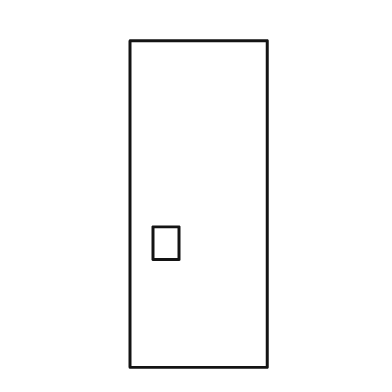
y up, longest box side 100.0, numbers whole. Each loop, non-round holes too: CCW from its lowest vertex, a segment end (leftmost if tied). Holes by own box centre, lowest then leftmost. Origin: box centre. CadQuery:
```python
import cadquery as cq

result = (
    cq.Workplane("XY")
    .moveTo(-21.0, -50.0)
    .lineTo(21.0, -50.0)
    .lineTo(21.0, 50.0)
    .lineTo(-21.0, 50.0)
    .close()
    .moveTo(-14.0, -17.0)
    .lineTo(-6.0, -17.0)
    .lineTo(-6.0, -7.0)
    .lineTo(-14.0, -7.0)
    .close()
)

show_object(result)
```